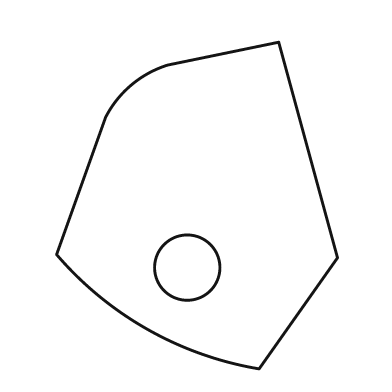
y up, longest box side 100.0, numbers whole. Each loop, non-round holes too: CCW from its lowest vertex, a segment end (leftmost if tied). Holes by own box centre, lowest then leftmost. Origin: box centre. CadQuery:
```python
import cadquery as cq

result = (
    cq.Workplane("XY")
    .moveTo(19.0, -50.0)
    .lineTo(43.0, -16.0)
    .lineTo(25.0, 50.0)
    .lineTo(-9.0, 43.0)
    .threePointArc((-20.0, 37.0), (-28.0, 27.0))
    .lineTo(-43.0, -15.0)
    .threePointArc((-15.0, -38.0), (19.0, -50.0))
    .close()
    .moveTo(-3.0, -19.0)
    .circle(10.0)
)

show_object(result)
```